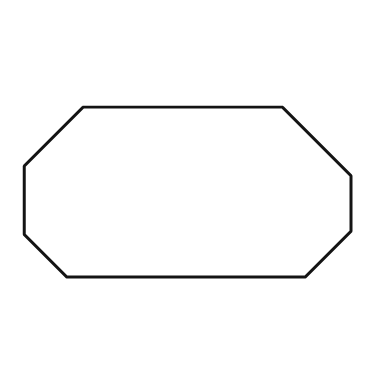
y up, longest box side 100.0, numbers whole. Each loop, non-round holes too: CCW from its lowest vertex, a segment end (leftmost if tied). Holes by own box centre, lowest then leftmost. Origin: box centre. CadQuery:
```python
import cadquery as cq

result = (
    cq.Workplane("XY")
    .moveTo(-37.0, -26.0)
    .lineTo(36.0, -26.0)
    .lineTo(50.0, -12.0)
    .lineTo(50.0, 5.0)
    .lineTo(29.0, 26.0)
    .lineTo(-32.0, 26.0)
    .lineTo(-50.0, 8.0)
    .lineTo(-50.0, -13.0)
    .close()
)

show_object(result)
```